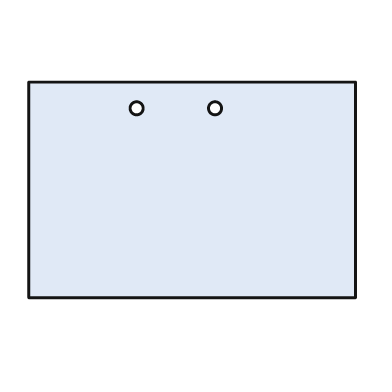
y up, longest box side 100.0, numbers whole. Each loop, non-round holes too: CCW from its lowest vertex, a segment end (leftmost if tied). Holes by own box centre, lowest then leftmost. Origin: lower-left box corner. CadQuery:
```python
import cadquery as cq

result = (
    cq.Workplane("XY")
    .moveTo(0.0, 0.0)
    .lineTo(100.0, 0.0)
    .lineTo(100.0, 66.0)
    .lineTo(0.0, 66.0)
    .close()
    .moveTo(33.0, 58.0)
    .circle(2.0)
    .moveTo(57.0, 58.0)
    .circle(2.0)
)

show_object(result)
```